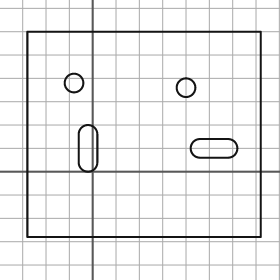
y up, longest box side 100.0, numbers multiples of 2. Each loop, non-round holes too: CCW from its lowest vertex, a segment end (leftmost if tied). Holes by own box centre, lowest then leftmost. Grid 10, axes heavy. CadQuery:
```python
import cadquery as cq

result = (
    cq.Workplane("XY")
    .moveTo(-28.0, -28.0)
    .lineTo(72.0, -28.0)
    .lineTo(72.0, 60.0)
    .lineTo(-28.0, 60.0)
    .close()
    .moveTo(-6.0, 4.0)
    .threePointArc((-2.0, 0.0), (2.0, 4.0))
    .lineTo(2.0, 16.0)
    .threePointArc((-2.0, 20.0), (-6.0, 16.0))
    .close()
    .moveTo(46.0, 6.0)
    .lineTo(58.0, 6.0)
    .threePointArc((62.0, 10.0), (58.0, 14.0))
    .lineTo(46.0, 14.0)
    .threePointArc((42.0, 10.0), (46.0, 6.0))
    .close()
    .moveTo(40.0, 36.0)
    .circle(4.0)
    .moveTo(-8.0, 38.0)
    .circle(4.0)
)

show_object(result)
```